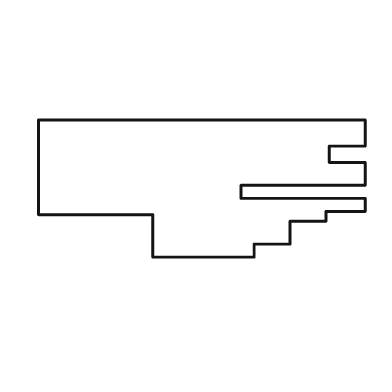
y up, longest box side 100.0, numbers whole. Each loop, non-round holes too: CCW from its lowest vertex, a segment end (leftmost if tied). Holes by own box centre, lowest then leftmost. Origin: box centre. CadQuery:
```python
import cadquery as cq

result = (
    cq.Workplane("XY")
    .moveTo(-15.0, -21.0)
    .lineTo(16.0, -21.0)
    .lineTo(16.0, -17.0)
    .lineTo(27.0, -17.0)
    .lineTo(27.0, -10.0)
    .lineTo(38.0, -10.0)
    .lineTo(38.0, -7.0)
    .lineTo(50.0, -7.0)
    .lineTo(50.0, -3.0)
    .lineTo(12.0, -3.0)
    .lineTo(12.0, 1.0)
    .lineTo(50.0, 1.0)
    .lineTo(50.0, 8.0)
    .lineTo(39.0, 8.0)
    .lineTo(39.0, 13.0)
    .lineTo(50.0, 13.0)
    .lineTo(50.0, 21.0)
    .lineTo(-50.0, 21.0)
    .lineTo(-50.0, -8.0)
    .lineTo(-15.0, -8.0)
    .close()
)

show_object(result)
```